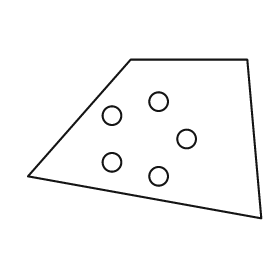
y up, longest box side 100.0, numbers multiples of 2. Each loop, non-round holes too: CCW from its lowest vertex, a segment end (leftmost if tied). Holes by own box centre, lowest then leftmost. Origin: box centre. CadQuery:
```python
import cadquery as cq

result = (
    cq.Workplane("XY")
    .moveTo(50.0, -34.0)
    .lineTo(44.0, 34.0)
    .lineTo(-6.0, 34.0)
    .lineTo(-50.0, -16.0)
    .close()
    .moveTo(6.0, -16.0)
    .circle(4.0)
    .moveTo(-14.0, -10.0)
    .circle(4.0)
    .moveTo(18.0, 0.0)
    .circle(4.0)
    .moveTo(-14.0, 10.0)
    .circle(4.0)
    .moveTo(6.0, 16.0)
    .circle(4.0)
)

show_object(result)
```